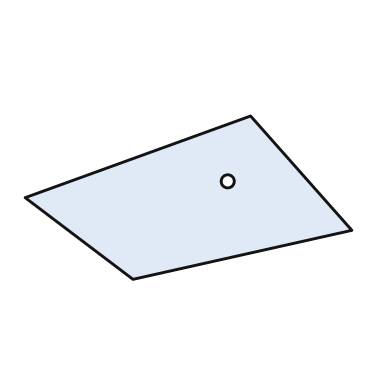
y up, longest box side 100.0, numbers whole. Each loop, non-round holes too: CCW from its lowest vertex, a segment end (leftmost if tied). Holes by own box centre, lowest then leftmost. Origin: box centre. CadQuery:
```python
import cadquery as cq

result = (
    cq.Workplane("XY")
    .moveTo(-17.0, -25.0)
    .lineTo(50.0, -10.0)
    .lineTo(19.0, 25.0)
    .lineTo(-50.0, 0.0)
    .close()
    .moveTo(12.0, 5.0)
    .circle(2.0)
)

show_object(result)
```